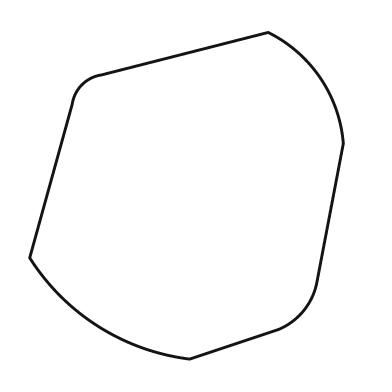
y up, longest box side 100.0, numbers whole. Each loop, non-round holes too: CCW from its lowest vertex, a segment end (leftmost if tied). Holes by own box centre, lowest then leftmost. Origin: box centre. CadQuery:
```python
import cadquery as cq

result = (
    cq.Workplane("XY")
    .moveTo(1.0, -50.0)
    .lineTo(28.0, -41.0)
    .threePointArc((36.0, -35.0), (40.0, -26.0))
    .lineTo(48.0, 16.0)
    .threePointArc((41.0, 36.0), (25.0, 50.0))
    .lineTo(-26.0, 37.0)
    .threePointArc((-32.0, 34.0), (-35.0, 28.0))
    .lineTo(-48.0, -19.0)
    .threePointArc((-27.0, -40.0), (1.0, -50.0))
    .close()
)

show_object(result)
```